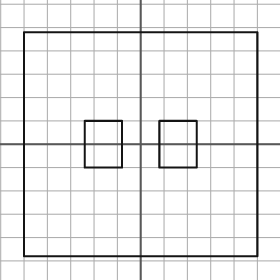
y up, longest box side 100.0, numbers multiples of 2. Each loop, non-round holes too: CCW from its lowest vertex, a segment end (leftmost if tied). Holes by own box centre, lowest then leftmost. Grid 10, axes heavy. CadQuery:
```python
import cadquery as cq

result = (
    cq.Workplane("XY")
    .moveTo(-50.0, -48.0)
    .lineTo(50.0, -48.0)
    .lineTo(50.0, 48.0)
    .lineTo(-50.0, 48.0)
    .close()
    .moveTo(-24.0, -10.0)
    .lineTo(-8.0, -10.0)
    .lineTo(-8.0, 10.0)
    .lineTo(-24.0, 10.0)
    .close()
    .moveTo(8.0, -10.0)
    .lineTo(24.0, -10.0)
    .lineTo(24.0, 10.0)
    .lineTo(8.0, 10.0)
    .close()
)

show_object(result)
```